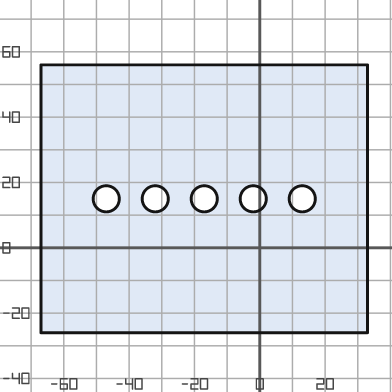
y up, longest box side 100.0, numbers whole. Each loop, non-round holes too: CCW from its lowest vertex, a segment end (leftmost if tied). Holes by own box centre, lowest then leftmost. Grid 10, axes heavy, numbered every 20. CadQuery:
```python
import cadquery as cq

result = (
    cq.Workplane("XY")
    .moveTo(-67.0, -26.0)
    .lineTo(33.0, -26.0)
    .lineTo(33.0, 56.0)
    .lineTo(-67.0, 56.0)
    .close()
    .moveTo(-47.0, 15.0)
    .circle(4.0)
    .moveTo(-32.0, 15.0)
    .circle(4.0)
    .moveTo(-17.0, 15.0)
    .circle(4.0)
    .moveTo(-2.0, 15.0)
    .circle(4.0)
    .moveTo(13.0, 15.0)
    .circle(4.0)
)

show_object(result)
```